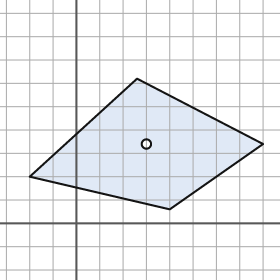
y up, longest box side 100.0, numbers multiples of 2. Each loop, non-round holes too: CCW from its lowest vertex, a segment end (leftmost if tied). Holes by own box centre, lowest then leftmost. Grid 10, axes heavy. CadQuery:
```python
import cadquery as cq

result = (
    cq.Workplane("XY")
    .moveTo(40.0, 6.0)
    .lineTo(80.0, 34.0)
    .lineTo(26.0, 62.0)
    .lineTo(-20.0, 20.0)
    .close()
    .moveTo(30.0, 34.0)
    .circle(2.0)
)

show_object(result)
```